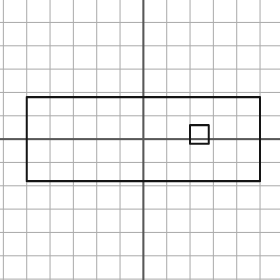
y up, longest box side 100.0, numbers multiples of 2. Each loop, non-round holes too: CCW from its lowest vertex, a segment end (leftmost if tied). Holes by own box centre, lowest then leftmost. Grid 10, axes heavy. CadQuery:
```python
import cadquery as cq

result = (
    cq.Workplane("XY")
    .moveTo(-50.0, -18.0)
    .lineTo(50.0, -18.0)
    .lineTo(50.0, 18.0)
    .lineTo(-50.0, 18.0)
    .close()
    .moveTo(20.0, -2.0)
    .lineTo(28.0, -2.0)
    .lineTo(28.0, 6.0)
    .lineTo(20.0, 6.0)
    .close()
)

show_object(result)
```